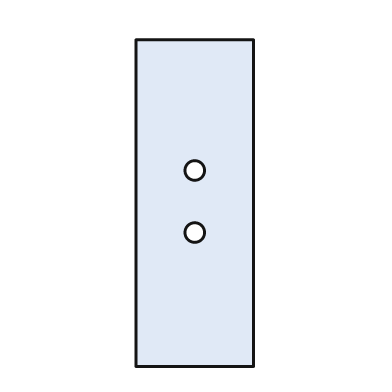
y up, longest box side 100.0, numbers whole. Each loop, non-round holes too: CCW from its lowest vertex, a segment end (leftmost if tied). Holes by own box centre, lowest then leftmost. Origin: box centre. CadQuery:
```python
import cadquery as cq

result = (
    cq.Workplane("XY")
    .moveTo(-18.0, -50.0)
    .lineTo(18.0, -50.0)
    .lineTo(18.0, 50.0)
    .lineTo(-18.0, 50.0)
    .close()
    .moveTo(0.0, -9.0)
    .circle(3.0)
    .moveTo(0.0, 10.0)
    .circle(3.0)
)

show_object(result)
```